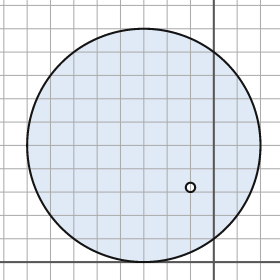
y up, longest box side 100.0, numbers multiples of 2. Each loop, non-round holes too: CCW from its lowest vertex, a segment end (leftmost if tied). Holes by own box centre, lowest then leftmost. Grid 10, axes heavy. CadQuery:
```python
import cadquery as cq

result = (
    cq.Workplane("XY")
    .moveTo(-30.0, 50.0)
    .circle(50.0)
    .moveTo(-10.0, 32.0)
    .circle(2.0)
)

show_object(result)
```